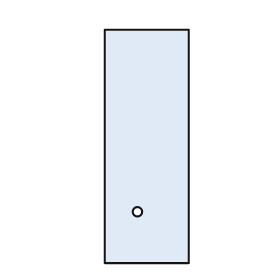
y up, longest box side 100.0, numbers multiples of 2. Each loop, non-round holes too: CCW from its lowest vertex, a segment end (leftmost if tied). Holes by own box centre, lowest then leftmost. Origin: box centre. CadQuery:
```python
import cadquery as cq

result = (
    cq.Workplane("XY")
    .moveTo(-18.0, -50.0)
    .lineTo(18.0, -50.0)
    .lineTo(18.0, 50.0)
    .lineTo(-18.0, 50.0)
    .close()
    .moveTo(-4.0, -28.0)
    .circle(2.0)
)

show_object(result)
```